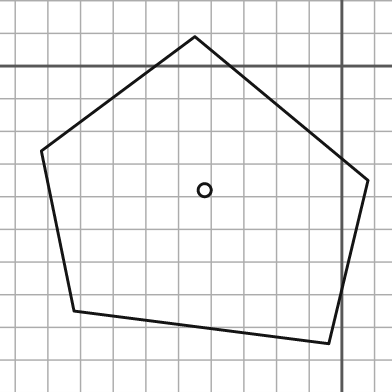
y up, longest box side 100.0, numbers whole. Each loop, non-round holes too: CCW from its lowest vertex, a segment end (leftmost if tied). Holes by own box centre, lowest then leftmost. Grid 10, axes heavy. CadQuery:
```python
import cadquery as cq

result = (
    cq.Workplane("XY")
    .moveTo(-4.0, -85.0)
    .lineTo(8.0, -35.0)
    .lineTo(-45.0, 9.0)
    .lineTo(-92.0, -26.0)
    .lineTo(-82.0, -75.0)
    .close()
    .moveTo(-42.0, -38.0)
    .circle(2.0)
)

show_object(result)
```